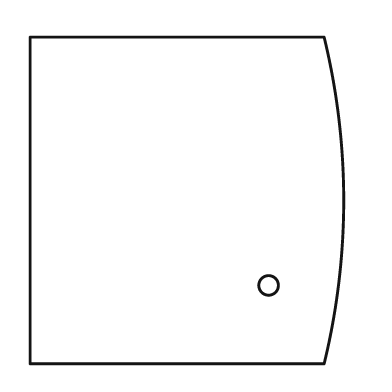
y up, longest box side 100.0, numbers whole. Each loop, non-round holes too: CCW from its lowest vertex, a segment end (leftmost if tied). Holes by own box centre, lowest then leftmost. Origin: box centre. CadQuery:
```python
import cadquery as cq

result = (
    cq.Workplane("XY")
    .moveTo(-48.0, -50.0)
    .lineTo(42.0, -50.0)
    .threePointArc((48.0, 0.0), (42.0, 50.0))
    .lineTo(-48.0, 50.0)
    .close()
    .moveTo(25.0, -26.0)
    .circle(3.0)
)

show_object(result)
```